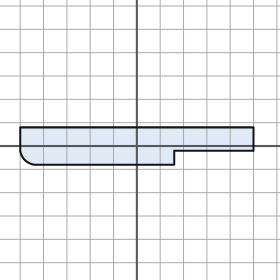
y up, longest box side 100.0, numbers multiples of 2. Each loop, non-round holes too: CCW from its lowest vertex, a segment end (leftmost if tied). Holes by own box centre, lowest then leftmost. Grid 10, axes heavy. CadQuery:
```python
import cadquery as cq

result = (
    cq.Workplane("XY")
    .moveTo(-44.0, -8.0)
    .lineTo(16.0, -8.0)
    .lineTo(16.0, -2.0)
    .lineTo(50.0, -2.0)
    .lineTo(50.0, 8.0)
    .lineTo(-50.0, 8.0)
    .lineTo(-50.0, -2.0)
    .threePointArc((-48.0, -6.0), (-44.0, -8.0))
    .close()
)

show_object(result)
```